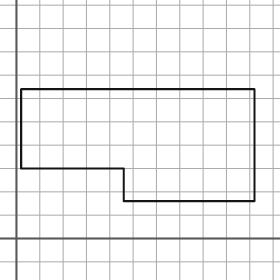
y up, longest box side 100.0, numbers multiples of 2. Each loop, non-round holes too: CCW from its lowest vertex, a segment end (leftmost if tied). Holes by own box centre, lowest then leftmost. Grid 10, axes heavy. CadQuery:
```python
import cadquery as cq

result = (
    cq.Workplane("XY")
    .moveTo(46.0, 16.0)
    .lineTo(102.0, 16.0)
    .lineTo(102.0, 64.0)
    .lineTo(2.0, 64.0)
    .lineTo(2.0, 30.0)
    .lineTo(46.0, 30.0)
    .close()
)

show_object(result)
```